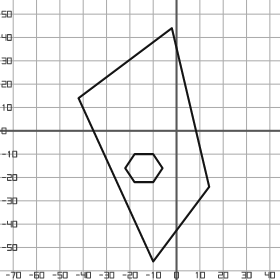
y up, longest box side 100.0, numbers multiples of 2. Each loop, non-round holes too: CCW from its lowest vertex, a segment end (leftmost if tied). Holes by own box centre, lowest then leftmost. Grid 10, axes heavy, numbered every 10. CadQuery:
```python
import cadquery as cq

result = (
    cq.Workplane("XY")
    .moveTo(-10.0, -56.0)
    .lineTo(14.0, -24.0)
    .lineTo(-2.0, 44.0)
    .lineTo(-42.0, 14.0)
    .close()
    .moveTo(-18.0, -22.0)
    .lineTo(-10.0, -22.0)
    .lineTo(-6.0, -16.0)
    .lineTo(-10.0, -10.0)
    .lineTo(-18.0, -10.0)
    .lineTo(-22.0, -16.0)
    .close()
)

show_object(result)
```